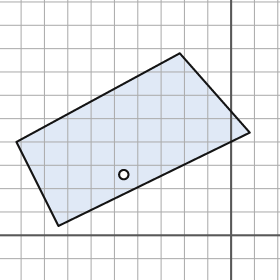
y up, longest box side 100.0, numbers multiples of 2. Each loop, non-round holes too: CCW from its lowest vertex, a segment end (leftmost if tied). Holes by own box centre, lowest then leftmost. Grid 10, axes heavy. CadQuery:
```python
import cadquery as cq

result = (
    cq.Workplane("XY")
    .moveTo(-74.0, 4.0)
    .lineTo(8.0, 44.0)
    .lineTo(-22.0, 78.0)
    .lineTo(-92.0, 40.0)
    .close()
    .moveTo(-46.0, 26.0)
    .circle(2.0)
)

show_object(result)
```